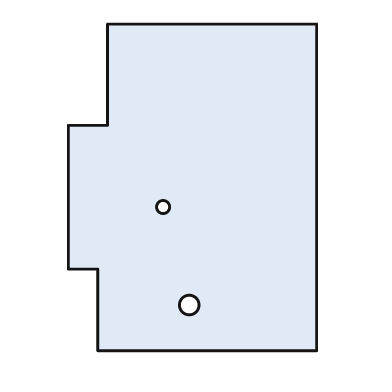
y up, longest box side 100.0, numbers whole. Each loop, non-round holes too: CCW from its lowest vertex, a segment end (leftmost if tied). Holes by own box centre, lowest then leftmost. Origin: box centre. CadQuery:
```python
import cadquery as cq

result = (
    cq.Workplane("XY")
    .moveTo(-29.0, -50.0)
    .lineTo(38.0, -50.0)
    .lineTo(38.0, 50.0)
    .lineTo(-26.0, 50.0)
    .lineTo(-26.0, 19.0)
    .lineTo(-38.0, 19.0)
    .lineTo(-38.0, -25.0)
    .lineTo(-29.0, -25.0)
    .close()
    .moveTo(-1.0, -36.0)
    .circle(3.0)
    .moveTo(-9.0, -6.0)
    .circle(2.0)
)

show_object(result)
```